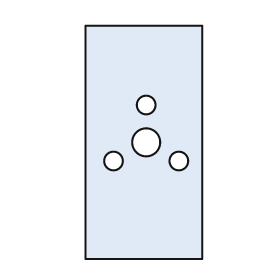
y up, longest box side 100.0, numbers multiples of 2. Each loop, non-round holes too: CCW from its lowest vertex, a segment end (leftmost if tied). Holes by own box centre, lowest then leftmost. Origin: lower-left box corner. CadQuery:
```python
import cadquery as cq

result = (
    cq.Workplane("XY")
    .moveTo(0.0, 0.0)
    .lineTo(50.0, 0.0)
    .lineTo(50.0, 100.0)
    .lineTo(0.0, 100.0)
    .close()
    .moveTo(12.0, 42.0)
    .circle(4.0)
    .moveTo(40.0, 42.0)
    .circle(4.0)
    .moveTo(26.0, 50.0)
    .circle(6.0)
    .moveTo(26.0, 66.0)
    .circle(4.0)
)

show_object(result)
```